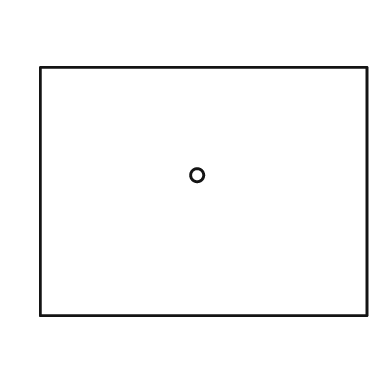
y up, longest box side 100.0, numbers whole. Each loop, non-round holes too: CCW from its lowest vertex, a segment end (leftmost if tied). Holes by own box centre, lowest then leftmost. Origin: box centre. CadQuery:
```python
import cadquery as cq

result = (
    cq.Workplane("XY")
    .moveTo(-50.0, -38.0)
    .lineTo(50.0, -38.0)
    .lineTo(50.0, 38.0)
    .lineTo(-50.0, 38.0)
    .close()
    .moveTo(-2.0, 5.0)
    .circle(2.0)
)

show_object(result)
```